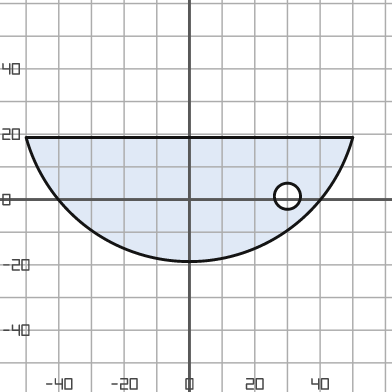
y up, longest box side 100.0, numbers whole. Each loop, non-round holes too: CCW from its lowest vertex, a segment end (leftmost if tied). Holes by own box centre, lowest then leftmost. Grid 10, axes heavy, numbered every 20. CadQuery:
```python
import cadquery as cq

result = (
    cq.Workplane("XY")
    .moveTo(-50.0, 19.0)
    .threePointArc((0.0, -19.0), (50.0, 19.0))
    .close()
    .moveTo(30.0, 1.0)
    .circle(4.0)
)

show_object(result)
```